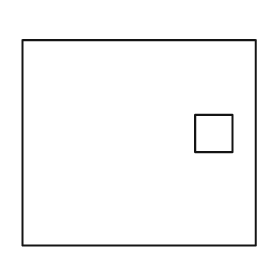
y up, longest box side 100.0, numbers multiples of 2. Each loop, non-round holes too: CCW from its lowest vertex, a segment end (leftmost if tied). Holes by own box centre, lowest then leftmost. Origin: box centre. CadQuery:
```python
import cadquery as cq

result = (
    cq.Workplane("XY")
    .moveTo(-50.0, -44.0)
    .lineTo(50.0, -44.0)
    .lineTo(50.0, 44.0)
    .lineTo(-50.0, 44.0)
    .close()
    .moveTo(24.0, -4.0)
    .lineTo(40.0, -4.0)
    .lineTo(40.0, 12.0)
    .lineTo(24.0, 12.0)
    .close()
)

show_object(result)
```